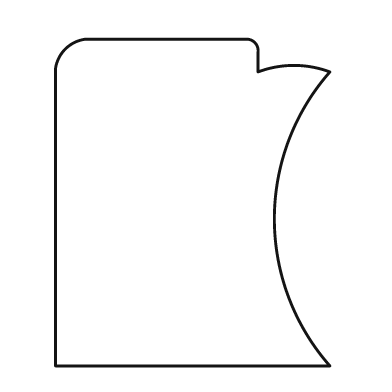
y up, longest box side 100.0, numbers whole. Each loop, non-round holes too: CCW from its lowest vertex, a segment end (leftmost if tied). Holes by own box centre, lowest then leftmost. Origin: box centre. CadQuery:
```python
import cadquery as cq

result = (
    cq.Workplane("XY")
    .moveTo(-42.0, -50.0)
    .lineTo(42.0, -50.0)
    .threePointArc((25.0, -5.0), (42.0, 40.0))
    .threePointArc((31.0, 42.0), (20.0, 40.0))
    .lineTo(20.0, 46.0)
    .threePointArc((19.0, 49.0), (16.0, 50.0))
    .lineTo(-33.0, 50.0)
    .threePointArc((-39.0, 47.0), (-42.0, 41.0))
    .close()
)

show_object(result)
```